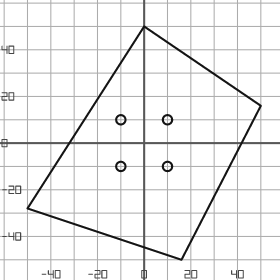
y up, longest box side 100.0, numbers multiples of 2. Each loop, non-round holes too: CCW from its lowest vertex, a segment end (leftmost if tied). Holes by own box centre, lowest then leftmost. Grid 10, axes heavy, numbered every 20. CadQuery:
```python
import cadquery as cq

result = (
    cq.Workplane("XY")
    .moveTo(16.0, -50.0)
    .lineTo(50.0, 16.0)
    .lineTo(0.0, 50.0)
    .lineTo(-50.0, -28.0)
    .close()
    .moveTo(-10.0, -10.0)
    .circle(2.0)
    .moveTo(10.0, -10.0)
    .circle(2.0)
    .moveTo(-10.0, 10.0)
    .circle(2.0)
    .moveTo(10.0, 10.0)
    .circle(2.0)
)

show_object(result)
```